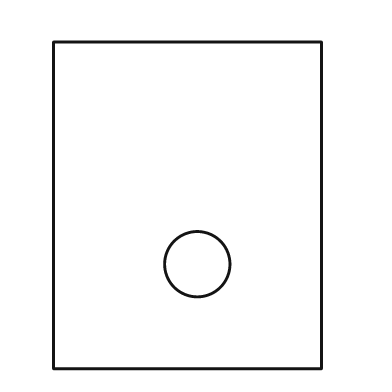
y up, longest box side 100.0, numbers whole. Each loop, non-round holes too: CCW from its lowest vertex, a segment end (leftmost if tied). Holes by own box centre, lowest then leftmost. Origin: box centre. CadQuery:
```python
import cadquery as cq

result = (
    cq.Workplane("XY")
    .moveTo(-41.0, -50.0)
    .lineTo(41.0, -50.0)
    .lineTo(41.0, 50.0)
    .lineTo(-41.0, 50.0)
    .close()
    .moveTo(3.0, -18.0)
    .circle(10.0)
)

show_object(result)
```